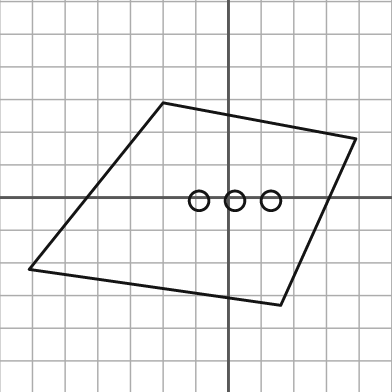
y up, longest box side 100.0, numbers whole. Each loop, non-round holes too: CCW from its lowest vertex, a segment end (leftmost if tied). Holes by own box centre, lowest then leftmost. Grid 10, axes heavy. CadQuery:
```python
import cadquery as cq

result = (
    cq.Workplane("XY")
    .moveTo(16.0, -33.0)
    .lineTo(39.0, 18.0)
    .lineTo(-20.0, 29.0)
    .lineTo(-61.0, -22.0)
    .close()
    .moveTo(-9.0, -1.0)
    .circle(3.0)
    .moveTo(2.0, -1.0)
    .circle(3.0)
    .moveTo(13.0, -1.0)
    .circle(3.0)
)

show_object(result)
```